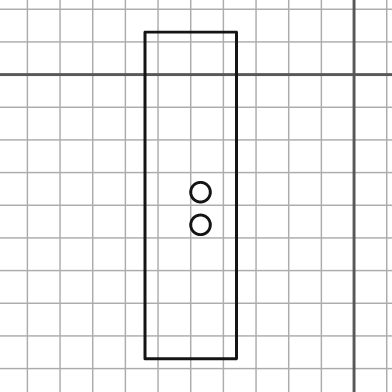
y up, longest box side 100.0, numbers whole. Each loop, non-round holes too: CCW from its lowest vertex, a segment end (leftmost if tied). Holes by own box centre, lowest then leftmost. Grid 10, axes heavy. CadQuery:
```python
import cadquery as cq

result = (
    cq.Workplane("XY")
    .moveTo(-64.0, -87.0)
    .lineTo(-36.0, -87.0)
    .lineTo(-36.0, 13.0)
    .lineTo(-64.0, 13.0)
    .close()
    .moveTo(-47.0, -46.0)
    .circle(3.0)
    .moveTo(-47.0, -36.0)
    .circle(3.0)
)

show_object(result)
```